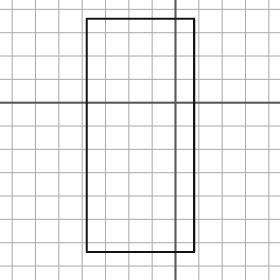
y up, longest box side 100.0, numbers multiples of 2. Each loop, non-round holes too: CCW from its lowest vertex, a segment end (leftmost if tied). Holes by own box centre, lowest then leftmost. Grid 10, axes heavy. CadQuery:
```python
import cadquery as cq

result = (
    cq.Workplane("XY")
    .moveTo(-38.0, -64.0)
    .lineTo(8.0, -64.0)
    .lineTo(8.0, 36.0)
    .lineTo(-38.0, 36.0)
    .close()
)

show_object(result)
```